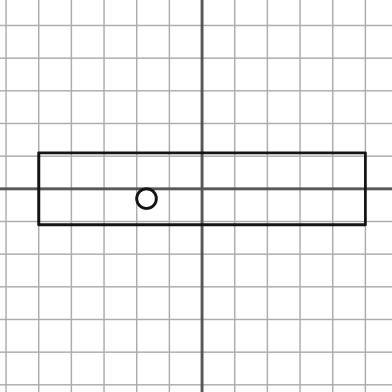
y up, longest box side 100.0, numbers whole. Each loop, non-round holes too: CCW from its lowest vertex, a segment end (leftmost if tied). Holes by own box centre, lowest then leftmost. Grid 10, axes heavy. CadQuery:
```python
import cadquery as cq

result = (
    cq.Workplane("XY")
    .moveTo(-50.0, -11.0)
    .lineTo(50.0, -11.0)
    .lineTo(50.0, 11.0)
    .lineTo(-50.0, 11.0)
    .close()
    .moveTo(-17.0, -3.0)
    .circle(3.0)
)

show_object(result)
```